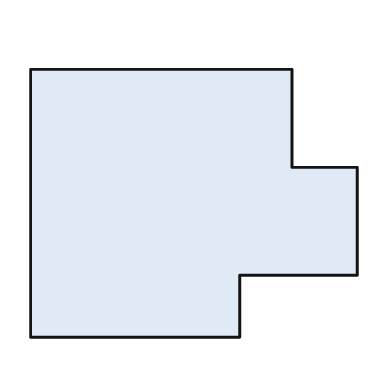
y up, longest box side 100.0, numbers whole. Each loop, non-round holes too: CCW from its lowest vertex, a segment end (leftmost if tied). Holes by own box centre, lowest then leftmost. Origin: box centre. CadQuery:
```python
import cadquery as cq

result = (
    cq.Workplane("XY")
    .moveTo(-50.0, -41.0)
    .lineTo(14.0, -41.0)
    .lineTo(14.0, -22.0)
    .lineTo(50.0, -22.0)
    .lineTo(50.0, 11.0)
    .lineTo(30.0, 11.0)
    .lineTo(30.0, 41.0)
    .lineTo(-50.0, 41.0)
    .close()
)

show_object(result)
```